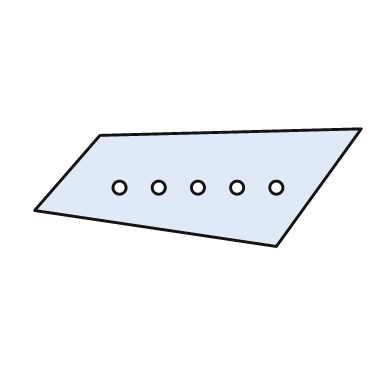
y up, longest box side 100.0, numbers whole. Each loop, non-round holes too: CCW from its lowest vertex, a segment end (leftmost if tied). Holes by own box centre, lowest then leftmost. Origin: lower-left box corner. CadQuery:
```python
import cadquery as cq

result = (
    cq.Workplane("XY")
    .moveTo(74.0, 0.0)
    .lineTo(100.0, 36.0)
    .lineTo(20.0, 34.0)
    .lineTo(0.0, 11.0)
    .close()
    .moveTo(26.0, 18.0)
    .circle(2.0)
    .moveTo(38.0, 18.0)
    .circle(2.0)
    .moveTo(50.0, 18.0)
    .circle(2.0)
    .moveTo(62.0, 18.0)
    .circle(2.0)
    .moveTo(74.0, 18.0)
    .circle(2.0)
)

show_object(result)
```